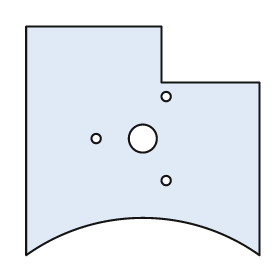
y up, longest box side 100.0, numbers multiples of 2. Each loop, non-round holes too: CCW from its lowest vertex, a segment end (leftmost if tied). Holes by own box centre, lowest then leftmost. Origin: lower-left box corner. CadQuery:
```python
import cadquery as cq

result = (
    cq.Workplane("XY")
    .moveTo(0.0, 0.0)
    .threePointArc((50.0, 16.0), (100.0, 0.0))
    .lineTo(100.0, 74.0)
    .lineTo(58.0, 74.0)
    .lineTo(58.0, 98.0)
    .lineTo(0.0, 98.0)
    .close()
    .moveTo(60.0, 32.0)
    .circle(2.0)
    .moveTo(30.0, 50.0)
    .circle(2.0)
    .moveTo(50.0, 50.0)
    .circle(6.0)
    .moveTo(60.0, 68.0)
    .circle(2.0)
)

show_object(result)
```